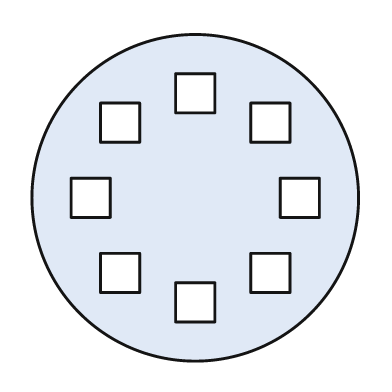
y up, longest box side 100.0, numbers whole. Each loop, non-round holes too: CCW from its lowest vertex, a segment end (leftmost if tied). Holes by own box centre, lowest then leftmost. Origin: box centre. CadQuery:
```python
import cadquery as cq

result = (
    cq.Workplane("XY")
    .moveTo(0.0, 0.0)
    .circle(50.0)
    .moveTo(-6.0, -38.0)
    .lineTo(6.0, -38.0)
    .lineTo(6.0, -26.0)
    .lineTo(-6.0, -26.0)
    .close()
    .moveTo(-29.0, -29.0)
    .lineTo(-17.0, -29.0)
    .lineTo(-17.0, -17.0)
    .lineTo(-29.0, -17.0)
    .close()
    .moveTo(17.0, -29.0)
    .lineTo(29.0, -29.0)
    .lineTo(29.0, -17.0)
    .lineTo(17.0, -17.0)
    .close()
    .moveTo(-38.0, -6.0)
    .lineTo(-26.0, -6.0)
    .lineTo(-26.0, 6.0)
    .lineTo(-38.0, 6.0)
    .close()
    .moveTo(26.0, -6.0)
    .lineTo(38.0, -6.0)
    .lineTo(38.0, 6.0)
    .lineTo(26.0, 6.0)
    .close()
    .moveTo(-29.0, 17.0)
    .lineTo(-17.0, 17.0)
    .lineTo(-17.0, 29.0)
    .lineTo(-29.0, 29.0)
    .close()
    .moveTo(17.0, 17.0)
    .lineTo(29.0, 17.0)
    .lineTo(29.0, 29.0)
    .lineTo(17.0, 29.0)
    .close()
    .moveTo(-6.0, 26.0)
    .lineTo(6.0, 26.0)
    .lineTo(6.0, 38.0)
    .lineTo(-6.0, 38.0)
    .close()
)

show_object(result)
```